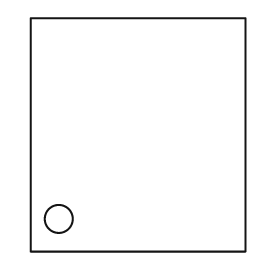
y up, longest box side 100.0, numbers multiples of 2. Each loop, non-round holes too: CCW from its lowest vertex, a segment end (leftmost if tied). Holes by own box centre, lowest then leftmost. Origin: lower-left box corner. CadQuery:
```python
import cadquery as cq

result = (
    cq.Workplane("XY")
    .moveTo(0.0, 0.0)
    .lineTo(92.0, 0.0)
    .lineTo(92.0, 100.0)
    .lineTo(0.0, 100.0)
    .close()
    .moveTo(12.0, 14.0)
    .circle(6.0)
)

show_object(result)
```